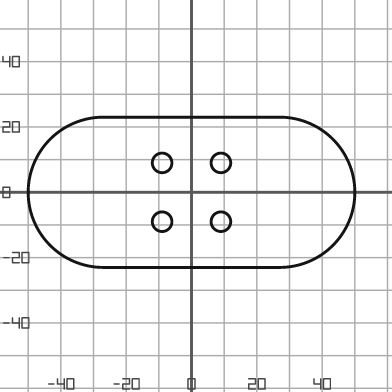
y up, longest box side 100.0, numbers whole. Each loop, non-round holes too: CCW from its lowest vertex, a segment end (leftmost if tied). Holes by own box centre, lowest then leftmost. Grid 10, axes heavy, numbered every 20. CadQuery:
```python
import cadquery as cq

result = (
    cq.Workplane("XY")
    .moveTo(-27.0, -23.0)
    .lineTo(27.0, -23.0)
    .threePointArc((50.0, 0.0), (27.0, 23.0))
    .lineTo(-27.0, 23.0)
    .threePointArc((-50.0, 0.0), (-27.0, -23.0))
    .close()
    .moveTo(-9.0, -9.0)
    .circle(3.0)
    .moveTo(9.0, -9.0)
    .circle(3.0)
    .moveTo(-9.0, 9.0)
    .circle(3.0)
    .moveTo(9.0, 9.0)
    .circle(3.0)
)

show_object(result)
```